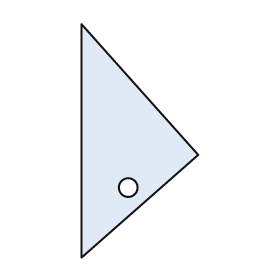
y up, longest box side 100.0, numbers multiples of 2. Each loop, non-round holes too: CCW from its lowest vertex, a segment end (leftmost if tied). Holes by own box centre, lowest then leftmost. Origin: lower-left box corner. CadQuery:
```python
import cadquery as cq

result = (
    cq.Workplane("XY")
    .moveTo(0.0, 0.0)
    .lineTo(50.0, 44.0)
    .lineTo(0.0, 100.0)
    .close()
    .moveTo(20.0, 30.0)
    .circle(4.0)
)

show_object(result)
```